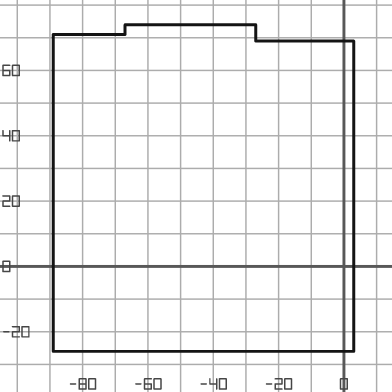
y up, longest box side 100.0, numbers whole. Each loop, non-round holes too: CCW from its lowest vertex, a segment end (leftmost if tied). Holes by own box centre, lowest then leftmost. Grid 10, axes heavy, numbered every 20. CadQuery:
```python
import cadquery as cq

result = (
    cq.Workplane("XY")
    .moveTo(-89.0, -26.0)
    .lineTo(3.0, -26.0)
    .lineTo(3.0, 69.0)
    .lineTo(-27.0, 69.0)
    .lineTo(-27.0, 74.0)
    .lineTo(-67.0, 74.0)
    .lineTo(-67.0, 71.0)
    .lineTo(-89.0, 71.0)
    .close()
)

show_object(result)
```